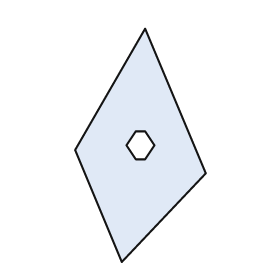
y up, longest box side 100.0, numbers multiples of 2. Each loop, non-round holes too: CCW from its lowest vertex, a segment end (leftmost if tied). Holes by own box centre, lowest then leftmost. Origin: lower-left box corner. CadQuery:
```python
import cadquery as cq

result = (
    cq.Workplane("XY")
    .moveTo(20.0, 0.0)
    .lineTo(56.0, 38.0)
    .lineTo(30.0, 100.0)
    .lineTo(0.0, 48.0)
    .close()
    .moveTo(26.0, 44.0)
    .lineTo(30.0, 44.0)
    .lineTo(34.0, 50.0)
    .lineTo(30.0, 56.0)
    .lineTo(26.0, 56.0)
    .lineTo(22.0, 50.0)
    .close()
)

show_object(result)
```